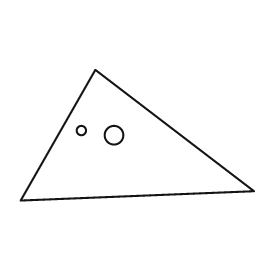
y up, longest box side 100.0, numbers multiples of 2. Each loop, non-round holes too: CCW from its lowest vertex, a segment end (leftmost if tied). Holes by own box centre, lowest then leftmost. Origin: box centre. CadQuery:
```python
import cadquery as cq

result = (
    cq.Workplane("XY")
    .moveTo(-50.0, -28.0)
    .lineTo(50.0, -24.0)
    .lineTo(-18.0, 28.0)
    .close()
    .moveTo(-10.0, 0.0)
    .circle(4.0)
    .moveTo(-24.0, 2.0)
    .circle(2.0)
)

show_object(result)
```